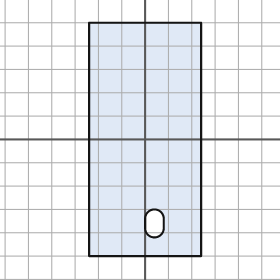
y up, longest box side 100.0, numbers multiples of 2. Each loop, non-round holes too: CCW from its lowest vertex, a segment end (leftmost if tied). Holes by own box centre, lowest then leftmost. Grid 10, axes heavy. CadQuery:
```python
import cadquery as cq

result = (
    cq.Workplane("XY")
    .moveTo(-24.0, -50.0)
    .lineTo(24.0, -50.0)
    .lineTo(24.0, 50.0)
    .lineTo(-24.0, 50.0)
    .close()
    .moveTo(0.0, -38.0)
    .threePointArc((4.0, -42.0), (8.0, -38.0))
    .lineTo(8.0, -34.0)
    .threePointArc((4.0, -30.0), (0.0, -34.0))
    .close()
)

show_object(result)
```